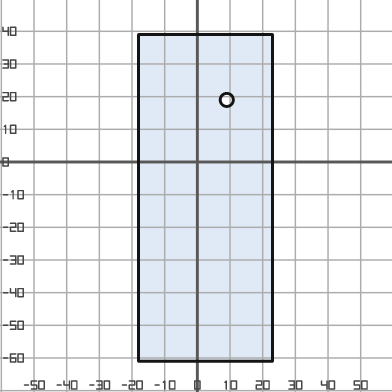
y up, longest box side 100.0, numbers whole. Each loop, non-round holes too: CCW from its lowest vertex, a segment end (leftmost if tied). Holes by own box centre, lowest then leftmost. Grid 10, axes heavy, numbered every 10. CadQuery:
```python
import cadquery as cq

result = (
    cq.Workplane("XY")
    .moveTo(-18.0, -61.0)
    .lineTo(23.0, -61.0)
    .lineTo(23.0, 39.0)
    .lineTo(-18.0, 39.0)
    .close()
    .moveTo(9.0, 19.0)
    .circle(2.0)
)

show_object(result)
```